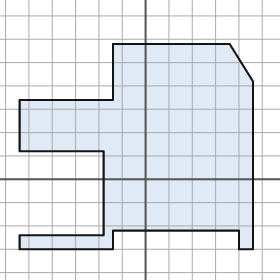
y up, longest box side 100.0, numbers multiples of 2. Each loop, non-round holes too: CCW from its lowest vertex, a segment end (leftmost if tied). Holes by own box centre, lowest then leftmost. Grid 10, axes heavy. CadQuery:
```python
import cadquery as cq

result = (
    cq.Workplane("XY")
    .moveTo(-54.0, -30.0)
    .lineTo(-14.0, -30.0)
    .lineTo(-14.0, -22.0)
    .lineTo(40.0, -22.0)
    .lineTo(40.0, -30.0)
    .lineTo(46.0, -30.0)
    .lineTo(46.0, 42.0)
    .lineTo(36.0, 58.0)
    .lineTo(-14.0, 58.0)
    .lineTo(-14.0, 34.0)
    .lineTo(-54.0, 34.0)
    .lineTo(-54.0, 12.0)
    .lineTo(-18.0, 12.0)
    .lineTo(-18.0, -24.0)
    .lineTo(-54.0, -24.0)
    .close()
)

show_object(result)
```